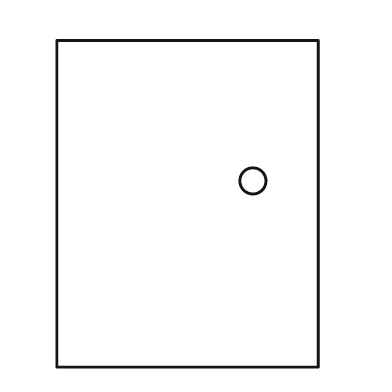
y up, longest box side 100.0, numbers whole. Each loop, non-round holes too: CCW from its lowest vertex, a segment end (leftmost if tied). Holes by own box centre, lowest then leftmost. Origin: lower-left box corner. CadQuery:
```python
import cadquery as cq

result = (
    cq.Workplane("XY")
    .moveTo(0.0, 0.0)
    .lineTo(80.0, 0.0)
    .lineTo(80.0, 100.0)
    .lineTo(0.0, 100.0)
    .close()
    .moveTo(60.0, 57.0)
    .circle(4.0)
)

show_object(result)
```